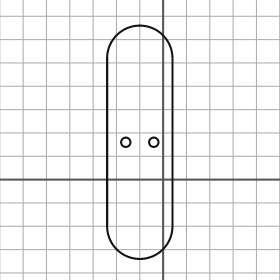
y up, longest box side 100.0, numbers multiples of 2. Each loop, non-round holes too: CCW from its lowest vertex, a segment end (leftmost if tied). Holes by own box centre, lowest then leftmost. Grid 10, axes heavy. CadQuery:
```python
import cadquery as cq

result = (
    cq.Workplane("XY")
    .moveTo(-24.0, -20.0)
    .threePointArc((-10.0, -34.0), (4.0, -20.0))
    .lineTo(4.0, 52.0)
    .threePointArc((-10.0, 66.0), (-24.0, 52.0))
    .close()
    .moveTo(-16.0, 16.0)
    .circle(2.0)
    .moveTo(-4.0, 16.0)
    .circle(2.0)
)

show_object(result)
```